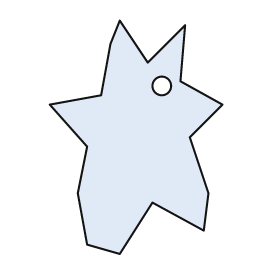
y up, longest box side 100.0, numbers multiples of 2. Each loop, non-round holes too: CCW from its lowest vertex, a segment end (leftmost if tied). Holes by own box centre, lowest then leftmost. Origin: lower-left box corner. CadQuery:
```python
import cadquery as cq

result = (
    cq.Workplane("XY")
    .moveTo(30.0, 0.0)
    .lineTo(44.0, 22.0)
    .lineTo(66.0, 10.0)
    .lineTo(68.0, 26.0)
    .lineTo(60.0, 50.0)
    .lineTo(74.0, 64.0)
    .lineTo(56.0, 74.0)
    .lineTo(58.0, 98.0)
    .lineTo(42.0, 82.0)
    .lineTo(30.0, 100.0)
    .lineTo(26.0, 90.0)
    .lineTo(22.0, 68.0)
    .lineTo(0.0, 64.0)
    .lineTo(16.0, 46.0)
    .lineTo(12.0, 26.0)
    .lineTo(16.0, 4.0)
    .close()
    .moveTo(48.0, 72.0)
    .circle(4.0)
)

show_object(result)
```